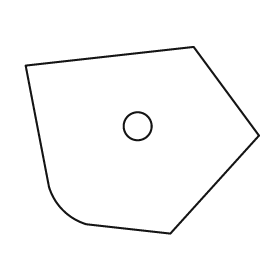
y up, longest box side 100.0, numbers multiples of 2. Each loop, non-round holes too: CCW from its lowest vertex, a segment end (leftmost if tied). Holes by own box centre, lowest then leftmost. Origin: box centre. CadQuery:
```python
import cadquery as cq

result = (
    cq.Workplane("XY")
    .moveTo(12.0, -40.0)
    .lineTo(50.0, 2.0)
    .lineTo(22.0, 40.0)
    .lineTo(-50.0, 32.0)
    .lineTo(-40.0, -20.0)
    .threePointArc((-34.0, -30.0), (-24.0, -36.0))
    .close()
    .moveTo(-2.0, 6.0)
    .circle(6.0)
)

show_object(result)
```